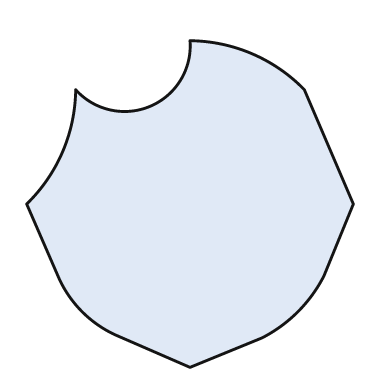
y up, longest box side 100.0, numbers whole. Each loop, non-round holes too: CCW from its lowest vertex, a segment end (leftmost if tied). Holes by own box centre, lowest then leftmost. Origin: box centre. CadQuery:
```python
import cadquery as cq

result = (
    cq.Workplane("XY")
    .moveTo(0.0, -50.0)
    .lineTo(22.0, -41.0)
    .threePointArc((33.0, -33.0), (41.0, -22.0))
    .lineTo(50.0, 0.0)
    .lineTo(35.0, 35.0)
    .threePointArc((19.0, 46.0), (0.0, 50.0))
    .threePointArc((-12.0, 30.0), (-35.0, 35.0))
    .threePointArc((-39.0, 16.0), (-50.0, 0.0))
    .lineTo(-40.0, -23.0)
    .threePointArc((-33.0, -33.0), (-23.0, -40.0))
    .close()
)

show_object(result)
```